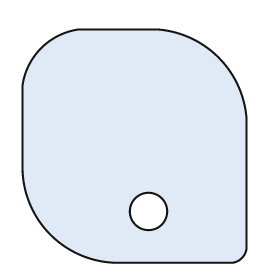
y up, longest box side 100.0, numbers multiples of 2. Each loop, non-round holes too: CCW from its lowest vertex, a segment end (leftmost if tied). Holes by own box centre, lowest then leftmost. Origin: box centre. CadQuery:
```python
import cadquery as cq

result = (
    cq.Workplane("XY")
    .moveTo(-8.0, -50.0)
    .lineTo(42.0, -50.0)
    .threePointArc((46.0, -48.0), (48.0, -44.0))
    .lineTo(48.0, 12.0)
    .threePointArc((36.0, 38.0), (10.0, 50.0))
    .lineTo(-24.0, 50.0)
    .threePointArc((-40.0, 42.0), (-48.0, 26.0))
    .lineTo(-48.0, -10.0)
    .threePointArc((-36.0, -38.0), (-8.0, -50.0))
    .close()
    .moveTo(6.0, -28.0)
    .circle(8.0)
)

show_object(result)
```